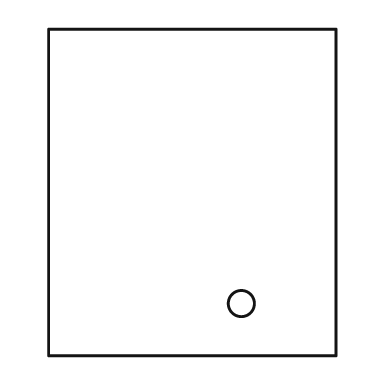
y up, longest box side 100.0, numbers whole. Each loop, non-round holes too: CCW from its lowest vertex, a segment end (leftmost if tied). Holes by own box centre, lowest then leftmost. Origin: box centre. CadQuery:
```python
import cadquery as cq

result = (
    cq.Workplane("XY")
    .moveTo(-44.0, -50.0)
    .lineTo(44.0, -50.0)
    .lineTo(44.0, 50.0)
    .lineTo(-44.0, 50.0)
    .close()
    .moveTo(15.0, -34.0)
    .circle(4.0)
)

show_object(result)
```